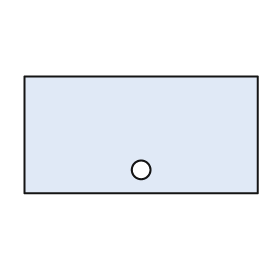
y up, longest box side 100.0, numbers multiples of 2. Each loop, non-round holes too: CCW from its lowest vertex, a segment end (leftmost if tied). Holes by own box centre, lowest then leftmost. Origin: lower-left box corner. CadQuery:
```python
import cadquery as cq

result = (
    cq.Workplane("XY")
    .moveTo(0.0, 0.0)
    .lineTo(100.0, 0.0)
    .lineTo(100.0, 50.0)
    .lineTo(0.0, 50.0)
    .close()
    .moveTo(50.0, 10.0)
    .circle(4.0)
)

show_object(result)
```